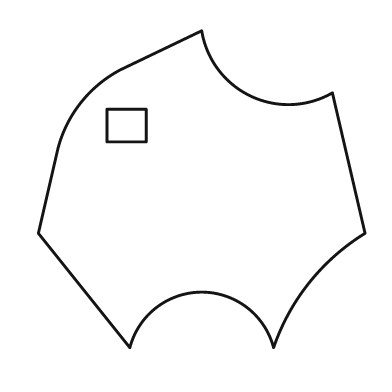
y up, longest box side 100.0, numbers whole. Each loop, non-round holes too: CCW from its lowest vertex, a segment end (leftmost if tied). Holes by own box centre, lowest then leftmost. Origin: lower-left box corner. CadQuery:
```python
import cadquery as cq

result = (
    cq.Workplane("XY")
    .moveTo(28.0, 0.0)
    .threePointArc((50.0, 17.0), (72.0, 0.0))
    .threePointArc((83.0, 20.0), (100.0, 35.0))
    .lineTo(90.0, 78.0)
    .threePointArc((65.0, 77.0), (50.0, 97.0))
    .lineTo(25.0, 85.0)
    .threePointArc((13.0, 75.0), (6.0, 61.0))
    .lineTo(0.0, 35.0)
    .close()
    .moveTo(21.0, 63.0)
    .lineTo(33.0, 63.0)
    .lineTo(33.0, 73.0)
    .lineTo(21.0, 73.0)
    .close()
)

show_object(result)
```